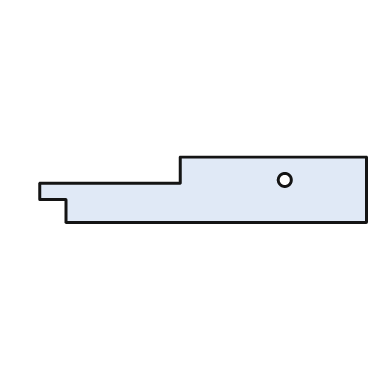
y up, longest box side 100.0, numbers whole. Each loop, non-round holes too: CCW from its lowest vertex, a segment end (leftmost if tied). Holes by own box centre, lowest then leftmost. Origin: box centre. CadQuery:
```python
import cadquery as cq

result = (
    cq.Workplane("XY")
    .moveTo(-42.0, -10.0)
    .lineTo(50.0, -10.0)
    .lineTo(50.0, 10.0)
    .lineTo(-7.0, 10.0)
    .lineTo(-7.0, 2.0)
    .lineTo(-50.0, 2.0)
    .lineTo(-50.0, -3.0)
    .lineTo(-42.0, -3.0)
    .close()
    .moveTo(25.0, 3.0)
    .circle(2.0)
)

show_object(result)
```